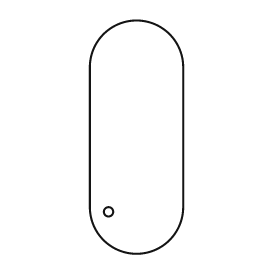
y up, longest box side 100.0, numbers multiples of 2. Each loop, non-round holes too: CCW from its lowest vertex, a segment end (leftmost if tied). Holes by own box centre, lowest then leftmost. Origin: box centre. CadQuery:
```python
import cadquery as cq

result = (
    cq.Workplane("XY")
    .moveTo(-20.0, -30.0)
    .threePointArc((0.0, -50.0), (20.0, -30.0))
    .lineTo(20.0, 30.0)
    .threePointArc((0.0, 50.0), (-20.0, 30.0))
    .close()
    .moveTo(-12.0, -32.0)
    .circle(2.0)
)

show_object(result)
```